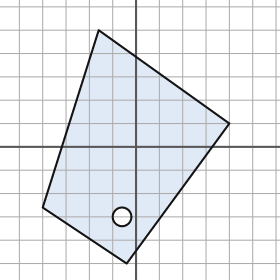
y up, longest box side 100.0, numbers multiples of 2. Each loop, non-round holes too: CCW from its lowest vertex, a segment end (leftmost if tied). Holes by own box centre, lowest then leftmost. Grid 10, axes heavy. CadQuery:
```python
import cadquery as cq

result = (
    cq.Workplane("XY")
    .moveTo(-4.0, -50.0)
    .lineTo(40.0, 10.0)
    .lineTo(-16.0, 50.0)
    .lineTo(-40.0, -26.0)
    .close()
    .moveTo(-6.0, -30.0)
    .circle(4.0)
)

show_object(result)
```